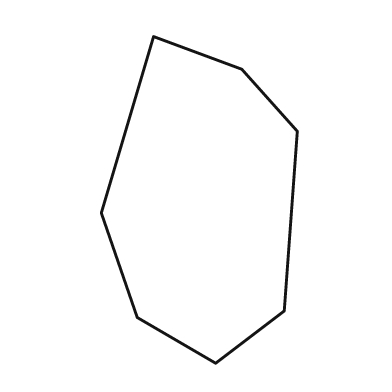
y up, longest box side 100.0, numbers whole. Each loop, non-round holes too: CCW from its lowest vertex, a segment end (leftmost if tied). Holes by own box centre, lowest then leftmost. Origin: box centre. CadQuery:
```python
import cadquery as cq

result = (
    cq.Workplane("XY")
    .moveTo(5.0, -50.0)
    .lineTo(26.0, -34.0)
    .lineTo(30.0, 21.0)
    .lineTo(13.0, 40.0)
    .lineTo(-14.0, 50.0)
    .lineTo(-30.0, -4.0)
    .lineTo(-19.0, -36.0)
    .close()
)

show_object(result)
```